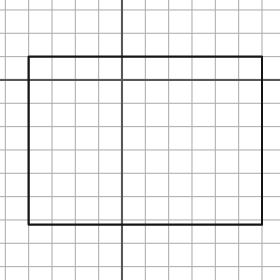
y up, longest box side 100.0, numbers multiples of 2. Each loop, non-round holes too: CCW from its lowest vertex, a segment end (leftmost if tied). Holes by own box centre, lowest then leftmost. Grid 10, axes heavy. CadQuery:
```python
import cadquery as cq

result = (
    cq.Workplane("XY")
    .moveTo(-40.0, -62.0)
    .lineTo(60.0, -62.0)
    .lineTo(60.0, 10.0)
    .lineTo(-40.0, 10.0)
    .close()
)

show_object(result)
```